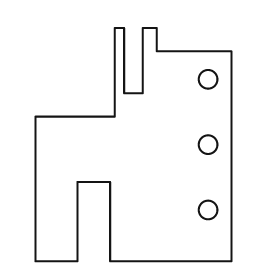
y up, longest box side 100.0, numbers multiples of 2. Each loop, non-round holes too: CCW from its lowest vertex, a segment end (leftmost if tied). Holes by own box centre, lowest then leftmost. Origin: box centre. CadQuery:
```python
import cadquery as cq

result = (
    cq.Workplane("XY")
    .moveTo(-42.0, -50.0)
    .lineTo(-24.0, -50.0)
    .lineTo(-24.0, -16.0)
    .lineTo(-10.0, -16.0)
    .lineTo(-10.0, -50.0)
    .lineTo(42.0, -50.0)
    .lineTo(42.0, 40.0)
    .lineTo(10.0, 40.0)
    .lineTo(10.0, 50.0)
    .lineTo(4.0, 50.0)
    .lineTo(4.0, 22.0)
    .lineTo(-4.0, 22.0)
    .lineTo(-4.0, 50.0)
    .lineTo(-8.0, 50.0)
    .lineTo(-8.0, 12.0)
    .lineTo(-42.0, 12.0)
    .close()
    .moveTo(32.0, -28.0)
    .circle(4.0)
    .moveTo(32.0, 0.0)
    .circle(4.0)
    .moveTo(32.0, 28.0)
    .circle(4.0)
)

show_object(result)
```